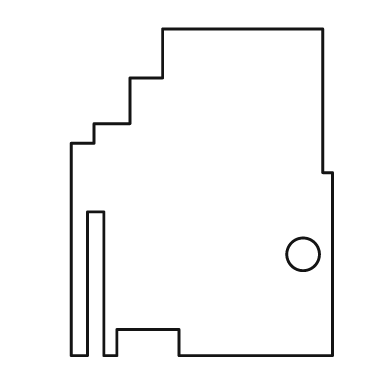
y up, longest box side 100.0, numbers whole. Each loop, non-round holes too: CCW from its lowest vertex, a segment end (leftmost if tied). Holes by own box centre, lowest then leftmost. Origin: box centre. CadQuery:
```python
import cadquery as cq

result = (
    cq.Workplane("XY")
    .moveTo(-40.0, -50.0)
    .lineTo(-35.0, -50.0)
    .lineTo(-35.0, -6.0)
    .lineTo(-30.0, -6.0)
    .lineTo(-30.0, -50.0)
    .lineTo(-26.0, -50.0)
    .lineTo(-26.0, -42.0)
    .lineTo(-7.0, -42.0)
    .lineTo(-7.0, -50.0)
    .lineTo(40.0, -50.0)
    .lineTo(40.0, 6.0)
    .lineTo(37.0, 6.0)
    .lineTo(37.0, 50.0)
    .lineTo(-12.0, 50.0)
    .lineTo(-12.0, 35.0)
    .lineTo(-22.0, 35.0)
    .lineTo(-22.0, 21.0)
    .lineTo(-33.0, 21.0)
    .lineTo(-33.0, 15.0)
    .lineTo(-40.0, 15.0)
    .close()
    .moveTo(31.0, -19.0)
    .circle(5.0)
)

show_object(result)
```